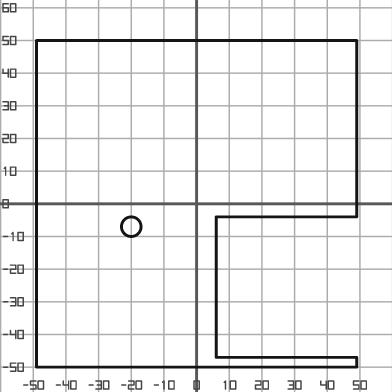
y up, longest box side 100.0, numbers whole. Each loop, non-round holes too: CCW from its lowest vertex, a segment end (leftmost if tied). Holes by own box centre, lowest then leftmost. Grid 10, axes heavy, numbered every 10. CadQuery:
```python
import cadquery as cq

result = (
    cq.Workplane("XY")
    .moveTo(-49.0, -50.0)
    .lineTo(49.0, -50.0)
    .lineTo(49.0, -47.0)
    .lineTo(6.0, -47.0)
    .lineTo(6.0, -4.0)
    .lineTo(49.0, -4.0)
    .lineTo(49.0, 50.0)
    .lineTo(-49.0, 50.0)
    .close()
    .moveTo(-20.0, -7.0)
    .circle(3.0)
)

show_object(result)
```